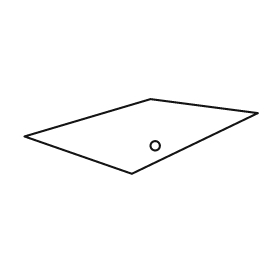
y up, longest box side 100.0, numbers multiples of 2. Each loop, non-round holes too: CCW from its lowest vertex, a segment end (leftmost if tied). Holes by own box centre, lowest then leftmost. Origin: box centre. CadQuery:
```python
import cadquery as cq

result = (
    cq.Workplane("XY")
    .moveTo(-4.0, -16.0)
    .lineTo(50.0, 10.0)
    .lineTo(4.0, 16.0)
    .lineTo(-50.0, 0.0)
    .close()
    .moveTo(6.0, -4.0)
    .circle(2.0)
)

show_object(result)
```